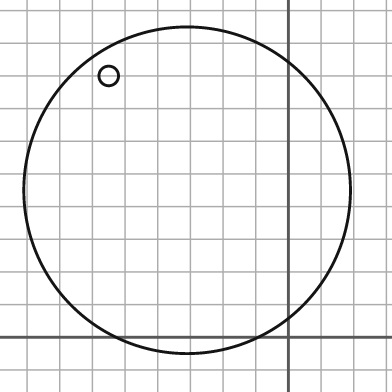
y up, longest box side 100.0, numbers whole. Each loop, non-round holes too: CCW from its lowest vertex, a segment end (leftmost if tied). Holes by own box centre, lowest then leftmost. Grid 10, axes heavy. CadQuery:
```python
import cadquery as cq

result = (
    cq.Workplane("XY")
    .moveTo(-31.0, 45.0)
    .circle(50.0)
    .moveTo(-55.0, 80.0)
    .circle(3.0)
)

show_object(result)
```